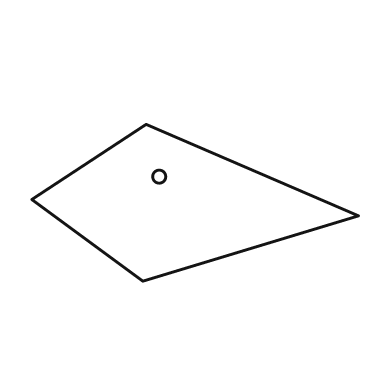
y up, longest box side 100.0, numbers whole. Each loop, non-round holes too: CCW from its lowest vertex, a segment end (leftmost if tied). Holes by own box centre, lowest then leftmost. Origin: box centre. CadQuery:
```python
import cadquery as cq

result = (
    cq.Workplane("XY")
    .moveTo(-16.0, -24.0)
    .lineTo(50.0, -4.0)
    .lineTo(-15.0, 24.0)
    .lineTo(-50.0, 1.0)
    .close()
    .moveTo(-11.0, 8.0)
    .circle(2.0)
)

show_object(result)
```